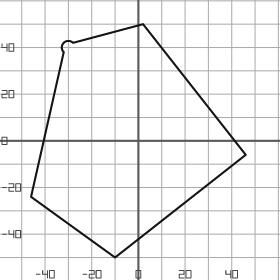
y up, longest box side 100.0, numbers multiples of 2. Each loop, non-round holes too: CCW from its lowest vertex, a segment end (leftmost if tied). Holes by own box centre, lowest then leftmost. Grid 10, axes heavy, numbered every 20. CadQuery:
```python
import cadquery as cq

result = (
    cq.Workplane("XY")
    .moveTo(-10.0, -50.0)
    .lineTo(46.0, -6.0)
    .lineTo(2.0, 50.0)
    .lineTo(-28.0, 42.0)
    .threePointArc((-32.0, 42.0), (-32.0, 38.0))
    .lineTo(-46.0, -24.0)
    .close()
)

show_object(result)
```